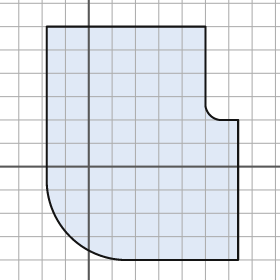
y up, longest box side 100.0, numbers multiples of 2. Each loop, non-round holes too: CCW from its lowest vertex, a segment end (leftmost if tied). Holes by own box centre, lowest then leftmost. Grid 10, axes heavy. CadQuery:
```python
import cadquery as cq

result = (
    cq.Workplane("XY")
    .moveTo(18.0, -40.0)
    .lineTo(64.0, -40.0)
    .lineTo(64.0, 20.0)
    .lineTo(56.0, 20.0)
    .threePointArc((52.0, 22.0), (50.0, 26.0))
    .lineTo(50.0, 60.0)
    .lineTo(-18.0, 60.0)
    .lineTo(-18.0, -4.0)
    .threePointArc((-8.0, -30.0), (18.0, -40.0))
    .close()
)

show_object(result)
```